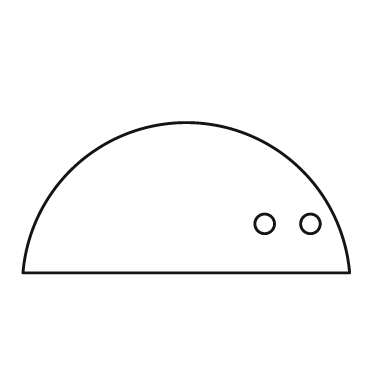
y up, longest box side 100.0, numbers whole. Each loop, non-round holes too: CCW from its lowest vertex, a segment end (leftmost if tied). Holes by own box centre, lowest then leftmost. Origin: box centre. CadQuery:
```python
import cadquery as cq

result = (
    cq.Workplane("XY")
    .moveTo(-50.0, -23.0)
    .lineTo(50.0, -23.0)
    .threePointArc((0.0, 23.0), (-50.0, -23.0))
    .close()
    .moveTo(24.0, -8.0)
    .circle(3.0)
    .moveTo(38.0, -8.0)
    .circle(3.0)
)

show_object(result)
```